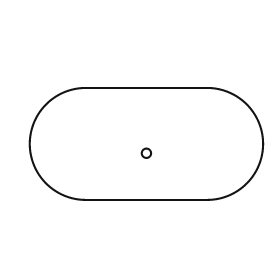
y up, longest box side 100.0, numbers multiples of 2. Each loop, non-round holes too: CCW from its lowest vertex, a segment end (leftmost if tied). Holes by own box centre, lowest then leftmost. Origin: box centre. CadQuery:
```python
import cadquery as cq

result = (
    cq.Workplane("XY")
    .moveTo(-26.0, -24.0)
    .lineTo(26.0, -24.0)
    .threePointArc((50.0, 0.0), (26.0, 24.0))
    .lineTo(-26.0, 24.0)
    .threePointArc((-50.0, 0.0), (-26.0, -24.0))
    .close()
    .moveTo(0.0, -4.0)
    .circle(2.0)
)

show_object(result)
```